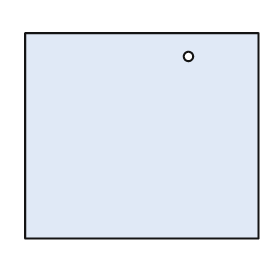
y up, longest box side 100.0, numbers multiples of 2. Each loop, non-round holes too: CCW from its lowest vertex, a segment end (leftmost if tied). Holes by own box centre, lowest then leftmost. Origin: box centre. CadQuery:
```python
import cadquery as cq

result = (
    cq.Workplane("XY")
    .moveTo(-50.0, -44.0)
    .lineTo(50.0, -44.0)
    .lineTo(50.0, 44.0)
    .lineTo(-50.0, 44.0)
    .close()
    .moveTo(20.0, 34.0)
    .circle(2.0)
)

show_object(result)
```